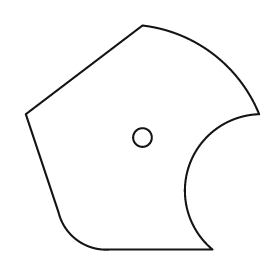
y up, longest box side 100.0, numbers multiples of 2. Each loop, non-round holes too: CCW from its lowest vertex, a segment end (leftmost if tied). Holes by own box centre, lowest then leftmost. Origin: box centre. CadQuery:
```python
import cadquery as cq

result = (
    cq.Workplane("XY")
    .moveTo(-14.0, -48.0)
    .lineTo(30.0, -48.0)
    .threePointArc((20.0, -12.0), (50.0, 10.0))
    .threePointArc((30.0, 36.0), (0.0, 48.0))
    .lineTo(-50.0, 10.0)
    .lineTo(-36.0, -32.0)
    .threePointArc((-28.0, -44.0), (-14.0, -48.0))
    .close()
    .moveTo(0.0, 0.0)
    .circle(4.0)
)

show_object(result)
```